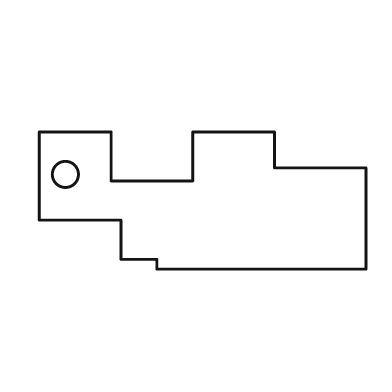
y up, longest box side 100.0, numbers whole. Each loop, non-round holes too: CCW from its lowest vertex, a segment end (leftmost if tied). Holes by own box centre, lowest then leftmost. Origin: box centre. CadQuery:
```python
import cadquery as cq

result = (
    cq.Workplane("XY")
    .moveTo(-14.0, -21.0)
    .lineTo(50.0, -21.0)
    .lineTo(50.0, 10.0)
    .lineTo(22.0, 10.0)
    .lineTo(22.0, 21.0)
    .lineTo(-3.0, 21.0)
    .lineTo(-3.0, 6.0)
    .lineTo(-28.0, 6.0)
    .lineTo(-28.0, 21.0)
    .lineTo(-50.0, 21.0)
    .lineTo(-50.0, -6.0)
    .lineTo(-25.0, -6.0)
    .lineTo(-25.0, -18.0)
    .lineTo(-14.0, -18.0)
    .close()
    .moveTo(-42.0, 8.0)
    .circle(4.0)
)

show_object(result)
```